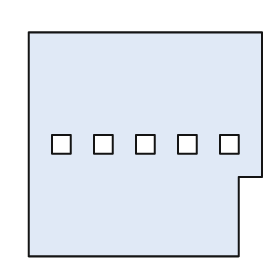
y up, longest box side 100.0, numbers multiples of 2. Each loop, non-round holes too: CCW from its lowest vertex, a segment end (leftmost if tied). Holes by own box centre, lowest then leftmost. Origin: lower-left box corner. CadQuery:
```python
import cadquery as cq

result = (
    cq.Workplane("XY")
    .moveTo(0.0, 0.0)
    .lineTo(90.0, 0.0)
    .lineTo(90.0, 34.0)
    .lineTo(100.0, 34.0)
    .lineTo(100.0, 96.0)
    .lineTo(0.0, 96.0)
    .close()
    .moveTo(10.0, 44.0)
    .lineTo(18.0, 44.0)
    .lineTo(18.0, 52.0)
    .lineTo(10.0, 52.0)
    .close()
    .moveTo(28.0, 44.0)
    .lineTo(36.0, 44.0)
    .lineTo(36.0, 52.0)
    .lineTo(28.0, 52.0)
    .close()
    .moveTo(46.0, 44.0)
    .lineTo(54.0, 44.0)
    .lineTo(54.0, 52.0)
    .lineTo(46.0, 52.0)
    .close()
    .moveTo(64.0, 44.0)
    .lineTo(72.0, 44.0)
    .lineTo(72.0, 52.0)
    .lineTo(64.0, 52.0)
    .close()
    .moveTo(82.0, 44.0)
    .lineTo(90.0, 44.0)
    .lineTo(90.0, 52.0)
    .lineTo(82.0, 52.0)
    .close()
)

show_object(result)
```